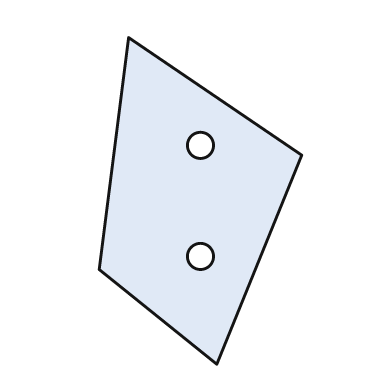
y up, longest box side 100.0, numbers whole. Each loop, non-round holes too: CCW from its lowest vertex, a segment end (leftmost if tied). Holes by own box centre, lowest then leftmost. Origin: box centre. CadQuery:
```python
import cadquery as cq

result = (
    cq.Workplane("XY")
    .moveTo(5.0, -50.0)
    .lineTo(31.0, 14.0)
    .lineTo(-22.0, 50.0)
    .lineTo(-31.0, -21.0)
    .close()
    .moveTo(0.0, -17.0)
    .circle(4.0)
    .moveTo(0.0, 17.0)
    .circle(4.0)
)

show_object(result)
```